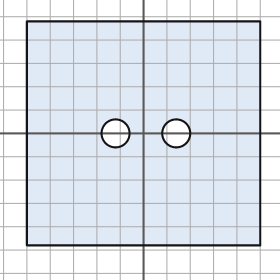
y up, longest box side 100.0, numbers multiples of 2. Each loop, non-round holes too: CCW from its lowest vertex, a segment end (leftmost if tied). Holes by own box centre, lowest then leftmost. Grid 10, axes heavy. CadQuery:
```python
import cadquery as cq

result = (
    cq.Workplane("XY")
    .moveTo(-50.0, -48.0)
    .lineTo(50.0, -48.0)
    .lineTo(50.0, 48.0)
    .lineTo(-50.0, 48.0)
    .close()
    .moveTo(-12.0, 0.0)
    .circle(6.0)
    .moveTo(14.0, 0.0)
    .circle(6.0)
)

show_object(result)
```